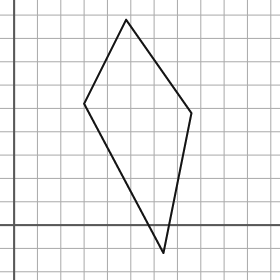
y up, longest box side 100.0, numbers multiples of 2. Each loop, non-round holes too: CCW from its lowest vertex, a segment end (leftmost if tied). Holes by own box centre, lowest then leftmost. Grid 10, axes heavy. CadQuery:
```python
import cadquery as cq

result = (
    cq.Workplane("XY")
    .moveTo(64.0, -12.0)
    .lineTo(76.0, 48.0)
    .lineTo(48.0, 88.0)
    .lineTo(30.0, 52.0)
    .close()
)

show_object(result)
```